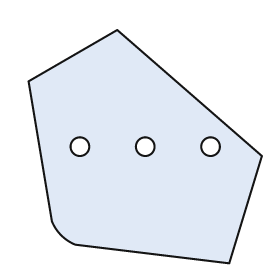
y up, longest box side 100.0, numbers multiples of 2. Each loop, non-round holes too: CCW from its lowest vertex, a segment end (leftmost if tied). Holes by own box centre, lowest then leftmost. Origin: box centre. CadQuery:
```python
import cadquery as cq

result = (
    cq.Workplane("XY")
    .moveTo(36.0, -50.0)
    .lineTo(50.0, -4.0)
    .lineTo(-12.0, 50.0)
    .lineTo(-50.0, 28.0)
    .lineTo(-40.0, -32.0)
    .threePointArc((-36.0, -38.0), (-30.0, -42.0))
    .close()
    .moveTo(-28.0, 0.0)
    .circle(4.0)
    .moveTo(0.0, 0.0)
    .circle(4.0)
    .moveTo(28.0, 0.0)
    .circle(4.0)
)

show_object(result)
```